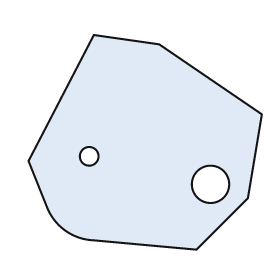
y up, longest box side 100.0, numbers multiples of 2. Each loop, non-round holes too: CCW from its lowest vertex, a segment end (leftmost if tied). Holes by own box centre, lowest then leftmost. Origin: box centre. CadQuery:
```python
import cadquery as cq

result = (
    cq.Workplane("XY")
    .moveTo(22.0, -46.0)
    .lineTo(44.0, -24.0)
    .lineTo(50.0, 12.0)
    .lineTo(6.0, 42.0)
    .lineTo(-22.0, 46.0)
    .lineTo(-50.0, -8.0)
    .lineTo(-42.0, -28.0)
    .threePointArc((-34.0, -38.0), (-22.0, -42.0))
    .close()
    .moveTo(28.0, -18.0)
    .circle(8.0)
    .moveTo(-24.0, -6.0)
    .circle(4.0)
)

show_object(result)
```